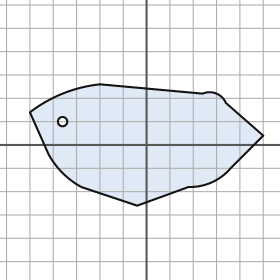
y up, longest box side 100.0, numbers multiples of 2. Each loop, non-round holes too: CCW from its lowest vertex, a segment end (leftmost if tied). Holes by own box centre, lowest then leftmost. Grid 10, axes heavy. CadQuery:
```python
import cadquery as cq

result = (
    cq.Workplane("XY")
    .moveTo(-4.0, -26.0)
    .lineTo(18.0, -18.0)
    .threePointArc((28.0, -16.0), (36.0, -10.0))
    .lineTo(50.0, 4.0)
    .lineTo(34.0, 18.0)
    .threePointArc((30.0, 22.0), (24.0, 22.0))
    .lineTo(-20.0, 26.0)
    .threePointArc((-36.0, 22.0), (-50.0, 14.0))
    .lineTo(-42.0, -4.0)
    .threePointArc((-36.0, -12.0), (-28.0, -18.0))
    .close()
    .moveTo(-36.0, 10.0)
    .circle(2.0)
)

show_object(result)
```